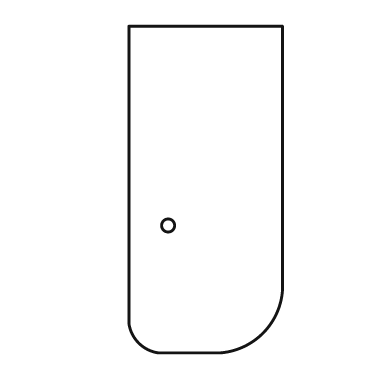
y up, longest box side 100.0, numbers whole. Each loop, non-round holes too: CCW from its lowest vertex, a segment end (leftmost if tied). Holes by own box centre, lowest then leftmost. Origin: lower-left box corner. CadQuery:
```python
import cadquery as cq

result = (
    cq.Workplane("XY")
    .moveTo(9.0, 0.0)
    .lineTo(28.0, 0.0)
    .threePointArc((41.0, 6.0), (47.0, 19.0))
    .lineTo(47.0, 100.0)
    .lineTo(0.0, 100.0)
    .lineTo(0.0, 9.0)
    .threePointArc((3.0, 3.0), (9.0, 0.0))
    .close()
    .moveTo(12.0, 39.0)
    .circle(2.0)
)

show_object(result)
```